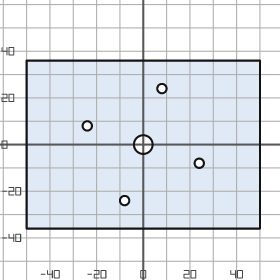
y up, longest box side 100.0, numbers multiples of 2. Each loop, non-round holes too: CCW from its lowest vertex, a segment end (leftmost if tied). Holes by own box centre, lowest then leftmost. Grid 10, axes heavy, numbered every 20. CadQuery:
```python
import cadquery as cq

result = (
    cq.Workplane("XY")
    .moveTo(-50.0, -36.0)
    .lineTo(50.0, -36.0)
    .lineTo(50.0, 36.0)
    .lineTo(-50.0, 36.0)
    .close()
    .moveTo(-8.0, -24.0)
    .circle(2.0)
    .moveTo(24.0, -8.0)
    .circle(2.0)
    .moveTo(0.0, 0.0)
    .circle(4.0)
    .moveTo(-24.0, 8.0)
    .circle(2.0)
    .moveTo(8.0, 24.0)
    .circle(2.0)
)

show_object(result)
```